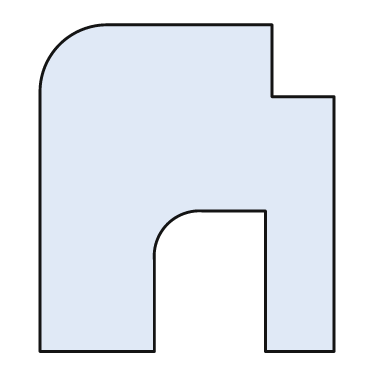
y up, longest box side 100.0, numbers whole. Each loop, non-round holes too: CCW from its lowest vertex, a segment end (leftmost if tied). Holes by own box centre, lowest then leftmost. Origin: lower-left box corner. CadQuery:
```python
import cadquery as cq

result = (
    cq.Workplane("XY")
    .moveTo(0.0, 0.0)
    .lineTo(35.0, 0.0)
    .lineTo(35.0, 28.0)
    .threePointArc((39.0, 39.0), (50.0, 43.0))
    .lineTo(69.0, 43.0)
    .lineTo(69.0, 0.0)
    .lineTo(90.0, 0.0)
    .lineTo(90.0, 78.0)
    .lineTo(71.0, 78.0)
    .lineTo(71.0, 100.0)
    .lineTo(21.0, 100.0)
    .threePointArc((6.0, 94.0), (0.0, 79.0))
    .close()
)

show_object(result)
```